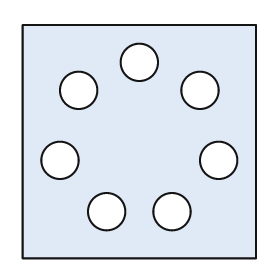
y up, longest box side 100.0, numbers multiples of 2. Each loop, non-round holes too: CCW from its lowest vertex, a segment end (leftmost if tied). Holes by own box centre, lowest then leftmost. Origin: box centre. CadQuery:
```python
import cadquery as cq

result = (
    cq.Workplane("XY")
    .moveTo(-50.0, -50.0)
    .lineTo(50.0, -50.0)
    .lineTo(50.0, 50.0)
    .lineTo(-50.0, 50.0)
    .close()
    .moveTo(-14.0, -30.0)
    .circle(8.0)
    .moveTo(14.0, -30.0)
    .circle(8.0)
    .moveTo(-34.0, -8.0)
    .circle(8.0)
    .moveTo(34.0, -8.0)
    .circle(8.0)
    .moveTo(-26.0, 22.0)
    .circle(8.0)
    .moveTo(26.0, 22.0)
    .circle(8.0)
    .moveTo(0.0, 34.0)
    .circle(8.0)
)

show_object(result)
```